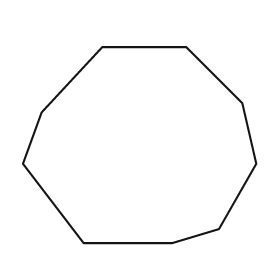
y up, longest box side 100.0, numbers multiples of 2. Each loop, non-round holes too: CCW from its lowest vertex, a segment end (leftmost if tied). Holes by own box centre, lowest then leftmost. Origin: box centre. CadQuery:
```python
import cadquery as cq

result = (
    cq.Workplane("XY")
    .moveTo(-24.0, -42.0)
    .lineTo(14.0, -42.0)
    .lineTo(34.0, -36.0)
    .lineTo(50.0, -8.0)
    .lineTo(44.0, 18.0)
    .lineTo(20.0, 42.0)
    .lineTo(-16.0, 42.0)
    .lineTo(-42.0, 14.0)
    .lineTo(-50.0, -8.0)
    .close()
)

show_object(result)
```